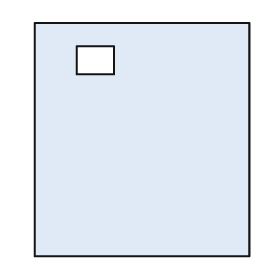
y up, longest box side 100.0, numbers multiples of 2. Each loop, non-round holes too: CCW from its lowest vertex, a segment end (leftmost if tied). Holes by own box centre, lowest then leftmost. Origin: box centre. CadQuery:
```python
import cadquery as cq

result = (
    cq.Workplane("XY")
    .moveTo(-46.0, -50.0)
    .lineTo(46.0, -50.0)
    .lineTo(46.0, 50.0)
    .lineTo(-46.0, 50.0)
    .close()
    .moveTo(-28.0, 28.0)
    .lineTo(-12.0, 28.0)
    .lineTo(-12.0, 40.0)
    .lineTo(-28.0, 40.0)
    .close()
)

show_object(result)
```